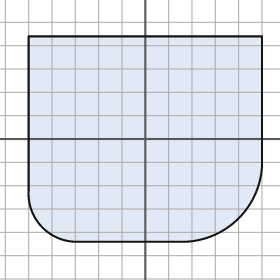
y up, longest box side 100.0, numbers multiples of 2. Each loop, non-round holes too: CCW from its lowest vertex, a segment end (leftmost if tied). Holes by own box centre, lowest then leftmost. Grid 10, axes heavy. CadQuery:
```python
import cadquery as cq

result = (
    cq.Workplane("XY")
    .moveTo(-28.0, -44.0)
    .lineTo(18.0, -44.0)
    .threePointArc((40.0, -34.0), (50.0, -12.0))
    .lineTo(50.0, 44.0)
    .lineTo(-50.0, 44.0)
    .lineTo(-50.0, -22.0)
    .threePointArc((-44.0, -38.0), (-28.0, -44.0))
    .close()
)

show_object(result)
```